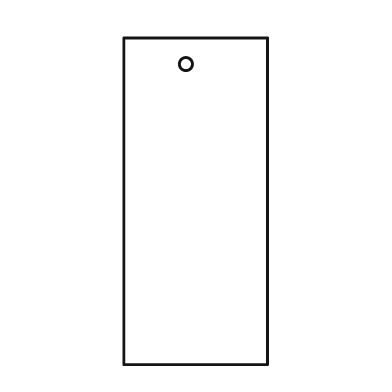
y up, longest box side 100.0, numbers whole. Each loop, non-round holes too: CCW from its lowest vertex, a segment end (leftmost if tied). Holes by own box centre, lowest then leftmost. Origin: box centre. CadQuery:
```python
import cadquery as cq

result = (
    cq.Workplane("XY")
    .moveTo(-22.0, -50.0)
    .lineTo(22.0, -50.0)
    .lineTo(22.0, 50.0)
    .lineTo(-22.0, 50.0)
    .close()
    .moveTo(-3.0, 42.0)
    .circle(2.0)
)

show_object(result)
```